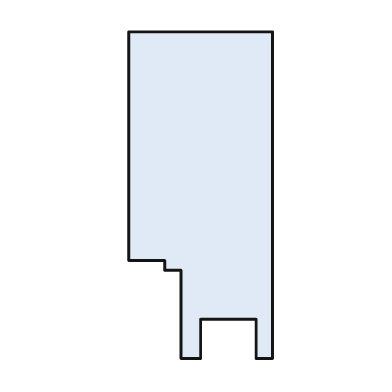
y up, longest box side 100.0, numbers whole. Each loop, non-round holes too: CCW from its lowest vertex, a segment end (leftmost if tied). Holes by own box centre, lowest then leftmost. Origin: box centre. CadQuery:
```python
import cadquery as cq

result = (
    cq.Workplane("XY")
    .moveTo(-6.0, -50.0)
    .lineTo(0.0, -50.0)
    .lineTo(0.0, -38.0)
    .lineTo(17.0, -38.0)
    .lineTo(17.0, -50.0)
    .lineTo(22.0, -50.0)
    .lineTo(22.0, 50.0)
    .lineTo(-22.0, 50.0)
    .lineTo(-22.0, -20.0)
    .lineTo(-11.0, -20.0)
    .lineTo(-11.0, -23.0)
    .lineTo(-6.0, -23.0)
    .close()
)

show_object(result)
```